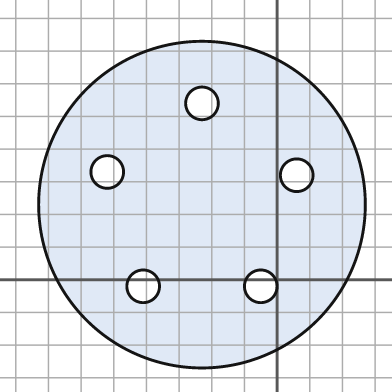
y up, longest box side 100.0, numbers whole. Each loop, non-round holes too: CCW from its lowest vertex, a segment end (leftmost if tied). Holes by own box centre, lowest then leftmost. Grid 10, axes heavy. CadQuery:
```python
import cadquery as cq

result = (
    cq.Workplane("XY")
    .moveTo(-23.0, 23.0)
    .circle(50.0)
    .moveTo(-41.0, -2.0)
    .circle(5.0)
    .moveTo(-5.0, -2.0)
    .circle(5.0)
    .moveTo(6.0, 32.0)
    .circle(5.0)
    .moveTo(-52.0, 33.0)
    .circle(5.0)
    .moveTo(-23.0, 54.0)
    .circle(5.0)
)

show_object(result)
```